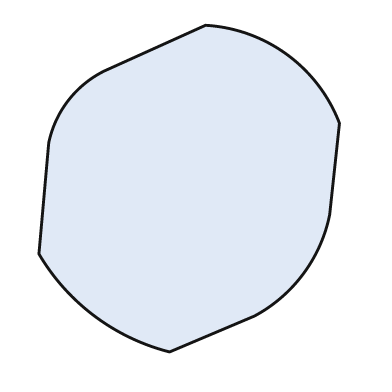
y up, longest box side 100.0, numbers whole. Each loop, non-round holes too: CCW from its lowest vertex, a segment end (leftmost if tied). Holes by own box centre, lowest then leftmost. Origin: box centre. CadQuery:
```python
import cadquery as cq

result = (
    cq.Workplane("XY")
    .moveTo(-6.0, -50.0)
    .lineTo(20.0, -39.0)
    .threePointArc((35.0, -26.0), (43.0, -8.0))
    .lineTo(46.0, 20.0)
    .threePointArc((30.0, 41.0), (5.0, 50.0))
    .lineTo(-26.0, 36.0)
    .threePointArc((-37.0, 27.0), (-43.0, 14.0))
    .lineTo(-46.0, -20.0)
    .threePointArc((-29.0, -39.0), (-6.0, -50.0))
    .close()
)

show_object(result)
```